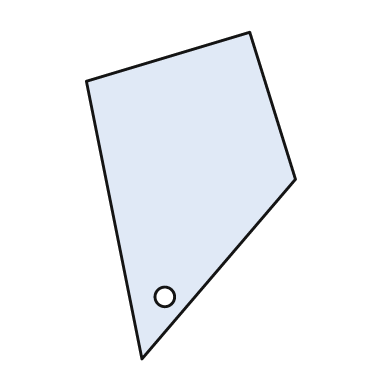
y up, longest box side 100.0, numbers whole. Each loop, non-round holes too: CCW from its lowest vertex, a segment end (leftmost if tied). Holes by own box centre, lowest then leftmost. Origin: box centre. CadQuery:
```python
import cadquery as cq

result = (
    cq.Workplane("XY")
    .moveTo(-15.0, -50.0)
    .lineTo(32.0, 5.0)
    .lineTo(18.0, 50.0)
    .lineTo(-32.0, 35.0)
    .close()
    .moveTo(-8.0, -31.0)
    .circle(3.0)
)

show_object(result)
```